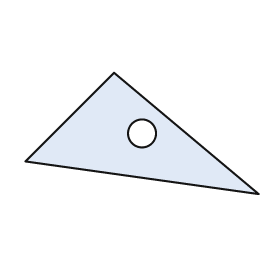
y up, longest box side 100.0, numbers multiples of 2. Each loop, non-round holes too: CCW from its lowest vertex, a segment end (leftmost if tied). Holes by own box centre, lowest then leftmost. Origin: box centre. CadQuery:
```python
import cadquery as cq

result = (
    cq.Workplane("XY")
    .moveTo(50.0, -26.0)
    .lineTo(-12.0, 26.0)
    .lineTo(-50.0, -12.0)
    .close()
    .moveTo(0.0, 0.0)
    .circle(6.0)
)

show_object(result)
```